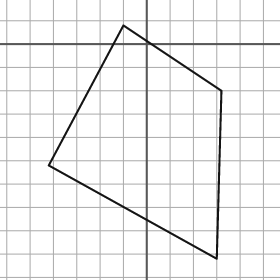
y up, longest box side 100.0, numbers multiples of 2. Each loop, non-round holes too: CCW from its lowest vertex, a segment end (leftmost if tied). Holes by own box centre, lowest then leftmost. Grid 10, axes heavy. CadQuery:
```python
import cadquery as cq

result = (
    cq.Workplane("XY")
    .moveTo(30.0, -92.0)
    .lineTo(32.0, -20.0)
    .lineTo(-10.0, 8.0)
    .lineTo(-42.0, -52.0)
    .close()
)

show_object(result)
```